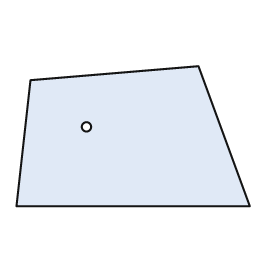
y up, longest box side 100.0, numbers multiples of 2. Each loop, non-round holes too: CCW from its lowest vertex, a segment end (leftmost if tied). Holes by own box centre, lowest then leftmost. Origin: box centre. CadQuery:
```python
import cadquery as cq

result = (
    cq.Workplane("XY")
    .moveTo(-50.0, -30.0)
    .lineTo(50.0, -30.0)
    .lineTo(28.0, 30.0)
    .lineTo(-44.0, 24.0)
    .close()
    .moveTo(-20.0, 4.0)
    .circle(2.0)
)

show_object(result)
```